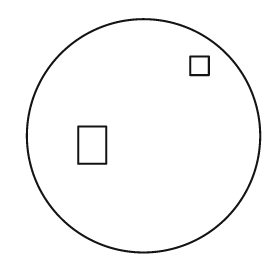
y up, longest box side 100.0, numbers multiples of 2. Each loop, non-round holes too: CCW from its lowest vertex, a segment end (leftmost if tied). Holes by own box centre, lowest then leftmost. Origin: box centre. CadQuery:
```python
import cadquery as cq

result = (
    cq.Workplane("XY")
    .moveTo(0.0, 0.0)
    .circle(50.0)
    .moveTo(-28.0, -12.0)
    .lineTo(-16.0, -12.0)
    .lineTo(-16.0, 4.0)
    .lineTo(-28.0, 4.0)
    .close()
    .moveTo(20.0, 26.0)
    .lineTo(28.0, 26.0)
    .lineTo(28.0, 34.0)
    .lineTo(20.0, 34.0)
    .close()
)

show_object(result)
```